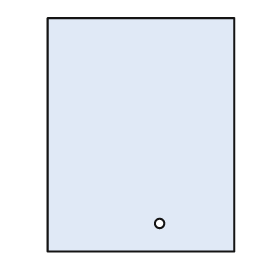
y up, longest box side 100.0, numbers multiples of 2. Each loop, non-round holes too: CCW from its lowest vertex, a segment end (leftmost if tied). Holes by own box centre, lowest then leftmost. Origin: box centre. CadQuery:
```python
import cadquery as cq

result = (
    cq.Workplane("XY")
    .moveTo(-40.0, -50.0)
    .lineTo(40.0, -50.0)
    .lineTo(40.0, 50.0)
    .lineTo(-40.0, 50.0)
    .close()
    .moveTo(8.0, -38.0)
    .circle(2.0)
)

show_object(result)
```